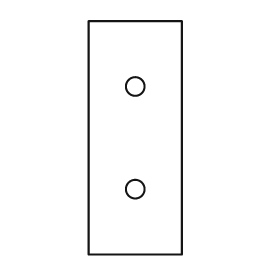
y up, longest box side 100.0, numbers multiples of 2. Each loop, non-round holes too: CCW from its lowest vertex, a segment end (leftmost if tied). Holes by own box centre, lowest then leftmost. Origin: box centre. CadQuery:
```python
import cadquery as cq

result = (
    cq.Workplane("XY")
    .moveTo(-20.0, -50.0)
    .lineTo(20.0, -50.0)
    .lineTo(20.0, 50.0)
    .lineTo(-20.0, 50.0)
    .close()
    .moveTo(0.0, -22.0)
    .circle(4.0)
    .moveTo(0.0, 22.0)
    .circle(4.0)
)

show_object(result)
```